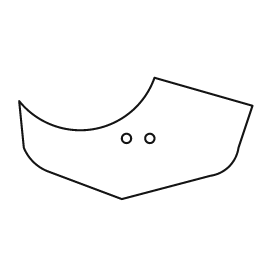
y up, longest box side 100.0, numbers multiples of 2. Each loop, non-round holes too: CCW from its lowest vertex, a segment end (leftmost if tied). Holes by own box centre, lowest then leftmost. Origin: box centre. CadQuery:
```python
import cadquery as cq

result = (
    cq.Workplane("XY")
    .moveTo(-6.0, -26.0)
    .lineTo(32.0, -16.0)
    .threePointArc((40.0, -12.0), (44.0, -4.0))
    .lineTo(50.0, 14.0)
    .lineTo(8.0, 26.0)
    .threePointArc((-18.0, 4.0), (-50.0, 16.0))
    .lineTo(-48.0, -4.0)
    .threePointArc((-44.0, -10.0), (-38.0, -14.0))
    .close()
    .moveTo(-4.0, 0.0)
    .circle(2.0)
    .moveTo(6.0, 0.0)
    .circle(2.0)
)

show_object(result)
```